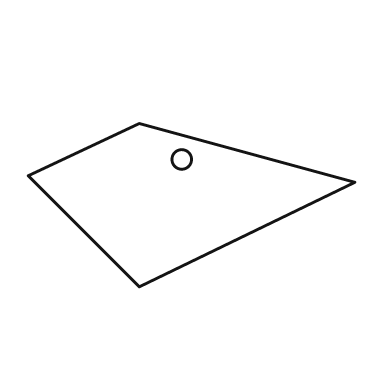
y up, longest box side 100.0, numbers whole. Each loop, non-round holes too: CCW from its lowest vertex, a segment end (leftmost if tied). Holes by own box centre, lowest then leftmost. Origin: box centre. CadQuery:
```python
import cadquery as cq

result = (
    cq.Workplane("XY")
    .moveTo(-16.0, -25.0)
    .lineTo(50.0, 7.0)
    .lineTo(-16.0, 25.0)
    .lineTo(-50.0, 9.0)
    .close()
    .moveTo(-3.0, 14.0)
    .circle(3.0)
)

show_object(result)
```